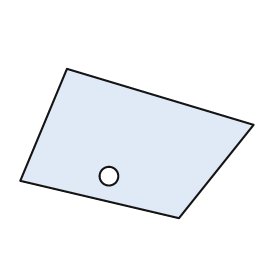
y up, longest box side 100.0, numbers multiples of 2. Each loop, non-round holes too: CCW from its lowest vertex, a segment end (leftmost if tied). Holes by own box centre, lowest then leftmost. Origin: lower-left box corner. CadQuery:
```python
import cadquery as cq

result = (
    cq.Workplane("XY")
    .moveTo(68.0, 0.0)
    .lineTo(100.0, 40.0)
    .lineTo(20.0, 64.0)
    .lineTo(0.0, 16.0)
    .close()
    .moveTo(38.0, 18.0)
    .circle(4.0)
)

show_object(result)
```